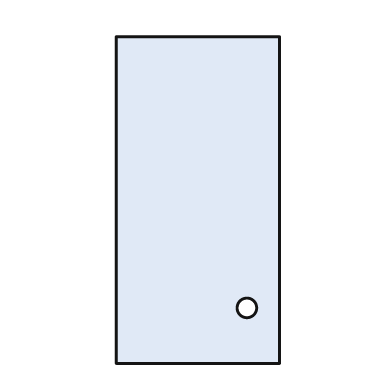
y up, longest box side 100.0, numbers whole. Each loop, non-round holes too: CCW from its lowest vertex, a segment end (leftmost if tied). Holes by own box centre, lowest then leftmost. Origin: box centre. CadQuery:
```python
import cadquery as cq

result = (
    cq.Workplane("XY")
    .moveTo(-25.0, -50.0)
    .lineTo(25.0, -50.0)
    .lineTo(25.0, 50.0)
    .lineTo(-25.0, 50.0)
    .close()
    .moveTo(15.0, -33.0)
    .circle(3.0)
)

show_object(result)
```